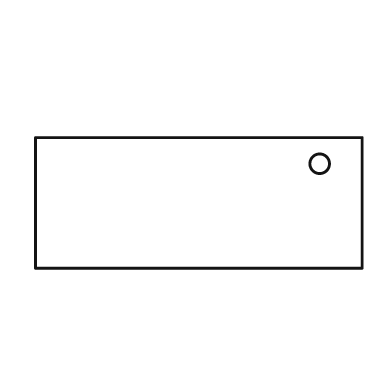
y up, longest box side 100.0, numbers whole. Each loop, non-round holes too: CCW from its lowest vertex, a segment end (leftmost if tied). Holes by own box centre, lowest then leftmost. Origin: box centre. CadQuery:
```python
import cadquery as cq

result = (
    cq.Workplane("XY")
    .moveTo(-50.0, -20.0)
    .lineTo(50.0, -20.0)
    .lineTo(50.0, 20.0)
    .lineTo(-50.0, 20.0)
    .close()
    .moveTo(37.0, 12.0)
    .circle(3.0)
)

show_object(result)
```